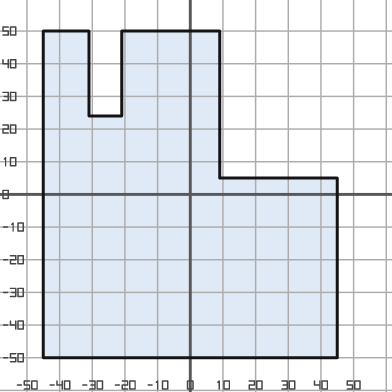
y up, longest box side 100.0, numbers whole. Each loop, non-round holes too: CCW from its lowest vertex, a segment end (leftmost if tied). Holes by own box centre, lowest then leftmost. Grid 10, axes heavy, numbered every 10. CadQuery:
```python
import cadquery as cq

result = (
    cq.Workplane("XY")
    .moveTo(-45.0, -50.0)
    .lineTo(45.0, -50.0)
    .lineTo(45.0, 5.0)
    .lineTo(9.0, 5.0)
    .lineTo(9.0, 50.0)
    .lineTo(-21.0, 50.0)
    .lineTo(-21.0, 24.0)
    .lineTo(-31.0, 24.0)
    .lineTo(-31.0, 50.0)
    .lineTo(-45.0, 50.0)
    .close()
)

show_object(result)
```